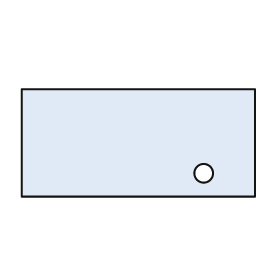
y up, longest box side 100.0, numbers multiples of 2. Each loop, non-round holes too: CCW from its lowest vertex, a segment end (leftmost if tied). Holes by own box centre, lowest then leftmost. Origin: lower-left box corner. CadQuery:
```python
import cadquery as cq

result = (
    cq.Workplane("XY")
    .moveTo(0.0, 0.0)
    .lineTo(100.0, 0.0)
    .lineTo(100.0, 46.0)
    .lineTo(0.0, 46.0)
    .close()
    .moveTo(78.0, 10.0)
    .circle(4.0)
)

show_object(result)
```